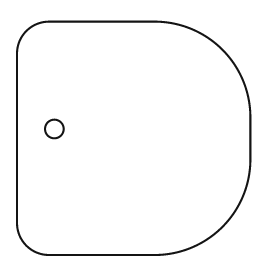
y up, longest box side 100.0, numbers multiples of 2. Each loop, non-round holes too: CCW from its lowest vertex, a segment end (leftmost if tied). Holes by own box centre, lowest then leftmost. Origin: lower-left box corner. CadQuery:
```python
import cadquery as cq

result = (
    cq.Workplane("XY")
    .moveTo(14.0, 0.0)
    .lineTo(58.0, 0.0)
    .threePointArc((88.0, 12.0), (100.0, 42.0))
    .lineTo(100.0, 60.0)
    .threePointArc((88.0, 88.0), (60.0, 100.0))
    .lineTo(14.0, 100.0)
    .threePointArc((4.0, 96.0), (0.0, 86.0))
    .lineTo(0.0, 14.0)
    .threePointArc((4.0, 4.0), (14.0, 0.0))
    .close()
    .moveTo(16.0, 54.0)
    .circle(4.0)
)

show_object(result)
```